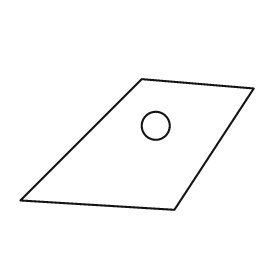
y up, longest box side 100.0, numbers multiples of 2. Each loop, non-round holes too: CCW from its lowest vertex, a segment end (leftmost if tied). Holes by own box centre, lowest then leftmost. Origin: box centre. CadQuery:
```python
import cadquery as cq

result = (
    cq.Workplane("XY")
    .moveTo(16.0, -28.0)
    .lineTo(50.0, 24.0)
    .lineTo(2.0, 28.0)
    .lineTo(-50.0, -24.0)
    .close()
    .moveTo(8.0, 8.0)
    .circle(6.0)
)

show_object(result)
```